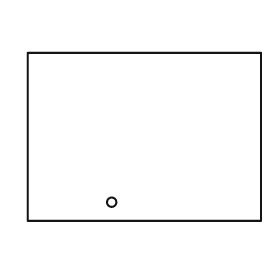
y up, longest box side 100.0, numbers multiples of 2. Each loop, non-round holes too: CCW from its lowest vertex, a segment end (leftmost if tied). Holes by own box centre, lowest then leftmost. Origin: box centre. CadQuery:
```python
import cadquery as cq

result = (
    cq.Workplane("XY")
    .moveTo(-50.0, -36.0)
    .lineTo(50.0, -36.0)
    .lineTo(50.0, 36.0)
    .lineTo(-50.0, 36.0)
    .close()
    .moveTo(-14.0, -28.0)
    .circle(2.0)
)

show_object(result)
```